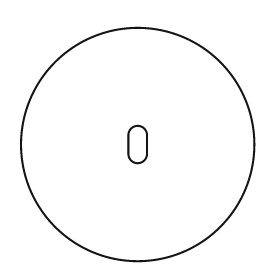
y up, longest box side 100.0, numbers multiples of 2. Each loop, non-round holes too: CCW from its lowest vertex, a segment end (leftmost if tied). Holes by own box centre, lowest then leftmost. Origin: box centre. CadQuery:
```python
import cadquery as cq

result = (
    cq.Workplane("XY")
    .moveTo(0.0, 0.0)
    .circle(50.0)
    .moveTo(-4.0, -4.0)
    .threePointArc((0.0, -8.0), (4.0, -4.0))
    .lineTo(4.0, 4.0)
    .threePointArc((0.0, 8.0), (-4.0, 4.0))
    .close()
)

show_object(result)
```